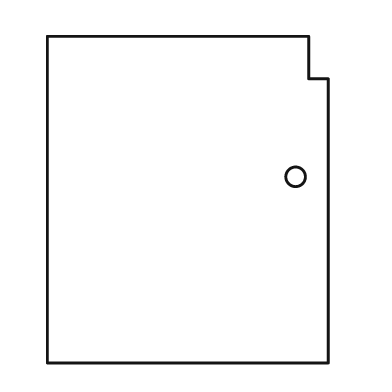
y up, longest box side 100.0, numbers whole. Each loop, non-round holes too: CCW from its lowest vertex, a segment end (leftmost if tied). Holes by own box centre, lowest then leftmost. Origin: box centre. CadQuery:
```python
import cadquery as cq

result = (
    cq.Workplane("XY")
    .moveTo(-43.0, -50.0)
    .lineTo(43.0, -50.0)
    .lineTo(43.0, 37.0)
    .lineTo(37.0, 37.0)
    .lineTo(37.0, 50.0)
    .lineTo(-43.0, 50.0)
    .close()
    .moveTo(33.0, 7.0)
    .circle(3.0)
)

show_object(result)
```